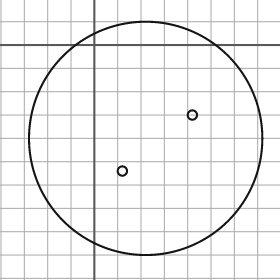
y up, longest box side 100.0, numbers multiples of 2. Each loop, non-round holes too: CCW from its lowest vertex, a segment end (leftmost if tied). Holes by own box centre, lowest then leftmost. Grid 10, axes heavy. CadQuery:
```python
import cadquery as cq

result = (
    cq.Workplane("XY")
    .moveTo(22.0, -40.0)
    .circle(50.0)
    .moveTo(12.0, -54.0)
    .circle(2.0)
    .moveTo(42.0, -30.0)
    .circle(2.0)
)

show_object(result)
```